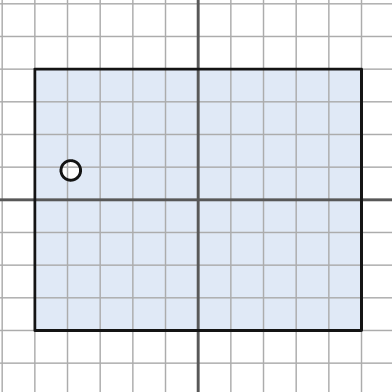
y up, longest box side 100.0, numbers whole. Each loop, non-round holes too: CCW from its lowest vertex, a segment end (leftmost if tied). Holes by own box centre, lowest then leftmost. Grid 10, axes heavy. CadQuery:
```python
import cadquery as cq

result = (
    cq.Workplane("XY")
    .moveTo(-50.0, -40.0)
    .lineTo(50.0, -40.0)
    .lineTo(50.0, 40.0)
    .lineTo(-50.0, 40.0)
    .close()
    .moveTo(-39.0, 9.0)
    .circle(3.0)
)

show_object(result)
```